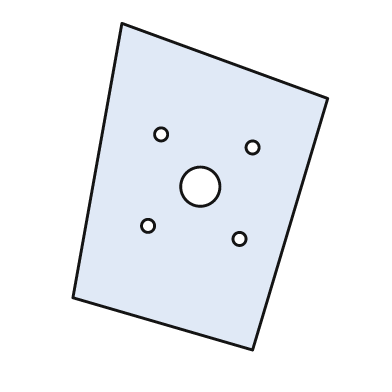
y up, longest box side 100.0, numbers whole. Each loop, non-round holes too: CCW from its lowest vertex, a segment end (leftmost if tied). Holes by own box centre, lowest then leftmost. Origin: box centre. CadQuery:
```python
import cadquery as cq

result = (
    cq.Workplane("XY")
    .moveTo(16.0, -50.0)
    .lineTo(39.0, 27.0)
    .lineTo(-24.0, 50.0)
    .lineTo(-39.0, -34.0)
    .close()
    .moveTo(12.0, -16.0)
    .circle(2.0)
    .moveTo(-16.0, -12.0)
    .circle(2.0)
    .moveTo(0.0, 0.0)
    .circle(6.0)
    .moveTo(16.0, 12.0)
    .circle(2.0)
    .moveTo(-12.0, 16.0)
    .circle(2.0)
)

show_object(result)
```